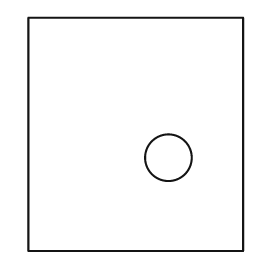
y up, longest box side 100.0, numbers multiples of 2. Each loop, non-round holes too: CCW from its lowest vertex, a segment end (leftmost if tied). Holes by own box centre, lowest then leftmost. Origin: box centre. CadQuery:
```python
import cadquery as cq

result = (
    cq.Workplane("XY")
    .moveTo(-46.0, -50.0)
    .lineTo(46.0, -50.0)
    .lineTo(46.0, 50.0)
    .lineTo(-46.0, 50.0)
    .close()
    .moveTo(14.0, -10.0)
    .circle(10.0)
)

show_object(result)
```